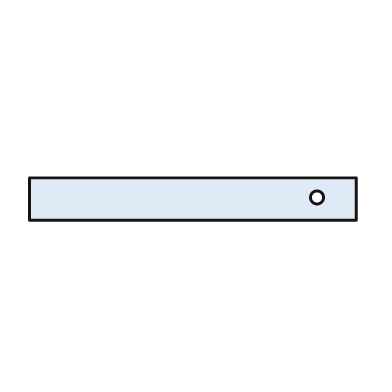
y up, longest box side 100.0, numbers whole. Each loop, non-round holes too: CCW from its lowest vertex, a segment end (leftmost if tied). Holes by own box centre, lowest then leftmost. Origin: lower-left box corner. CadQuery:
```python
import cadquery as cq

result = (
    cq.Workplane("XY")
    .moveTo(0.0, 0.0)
    .lineTo(100.0, 0.0)
    .lineTo(100.0, 13.0)
    .lineTo(0.0, 13.0)
    .close()
    .moveTo(88.0, 7.0)
    .circle(2.0)
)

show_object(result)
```